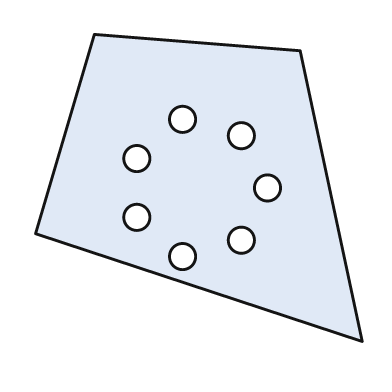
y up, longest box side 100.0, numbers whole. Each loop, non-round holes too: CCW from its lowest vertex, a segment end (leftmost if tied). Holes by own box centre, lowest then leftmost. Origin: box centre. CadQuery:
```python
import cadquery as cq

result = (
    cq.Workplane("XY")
    .moveTo(50.0, -47.0)
    .lineTo(31.0, 42.0)
    .lineTo(-32.0, 47.0)
    .lineTo(-50.0, -14.0)
    .close()
    .moveTo(-5.0, -21.0)
    .circle(4.0)
    .moveTo(13.0, -16.0)
    .circle(4.0)
    .moveTo(-19.0, -9.0)
    .circle(4.0)
    .moveTo(21.0, 0.0)
    .circle(4.0)
    .moveTo(-19.0, 9.0)
    .circle(4.0)
    .moveTo(13.0, 16.0)
    .circle(4.0)
    .moveTo(-5.0, 21.0)
    .circle(4.0)
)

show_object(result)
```